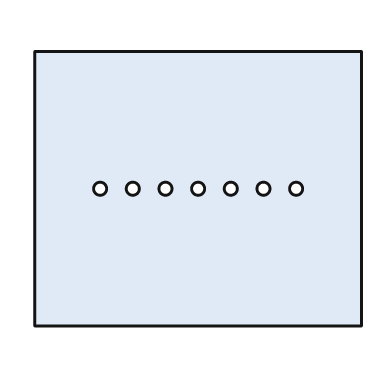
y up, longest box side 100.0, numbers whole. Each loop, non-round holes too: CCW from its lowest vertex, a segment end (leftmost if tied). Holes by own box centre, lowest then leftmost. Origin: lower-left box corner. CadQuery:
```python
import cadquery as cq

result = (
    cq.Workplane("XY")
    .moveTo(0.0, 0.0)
    .lineTo(100.0, 0.0)
    .lineTo(100.0, 84.0)
    .lineTo(0.0, 84.0)
    .close()
    .moveTo(20.0, 42.0)
    .circle(2.0)
    .moveTo(30.0, 42.0)
    .circle(2.0)
    .moveTo(40.0, 42.0)
    .circle(2.0)
    .moveTo(50.0, 42.0)
    .circle(2.0)
    .moveTo(60.0, 42.0)
    .circle(2.0)
    .moveTo(70.0, 42.0)
    .circle(2.0)
    .moveTo(80.0, 42.0)
    .circle(2.0)
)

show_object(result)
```